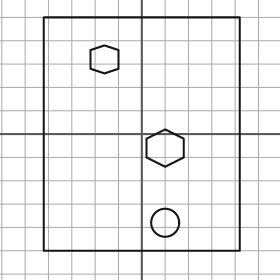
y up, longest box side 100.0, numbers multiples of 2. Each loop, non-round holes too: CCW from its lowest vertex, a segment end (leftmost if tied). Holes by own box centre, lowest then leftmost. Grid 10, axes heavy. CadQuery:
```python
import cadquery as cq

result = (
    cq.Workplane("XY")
    .moveTo(-42.0, -50.0)
    .lineTo(42.0, -50.0)
    .lineTo(42.0, 50.0)
    .lineTo(-42.0, 50.0)
    .close()
    .moveTo(10.0, -38.0)
    .circle(6.0)
    .moveTo(10.0, -14.0)
    .lineTo(18.0, -10.0)
    .lineTo(18.0, -2.0)
    .lineTo(10.0, 2.0)
    .lineTo(2.0, -2.0)
    .lineTo(2.0, -10.0)
    .close()
    .moveTo(-16.0, 26.0)
    .lineTo(-10.0, 28.0)
    .lineTo(-10.0, 36.0)
    .lineTo(-16.0, 38.0)
    .lineTo(-22.0, 36.0)
    .lineTo(-22.0, 28.0)
    .close()
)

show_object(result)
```